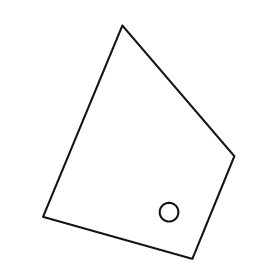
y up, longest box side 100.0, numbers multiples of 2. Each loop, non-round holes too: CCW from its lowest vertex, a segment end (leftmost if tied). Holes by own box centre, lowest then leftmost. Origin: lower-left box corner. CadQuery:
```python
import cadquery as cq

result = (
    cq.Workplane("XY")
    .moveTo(64.0, 0.0)
    .lineTo(82.0, 44.0)
    .lineTo(34.0, 100.0)
    .lineTo(0.0, 18.0)
    .close()
    .moveTo(54.0, 20.0)
    .circle(4.0)
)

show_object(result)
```